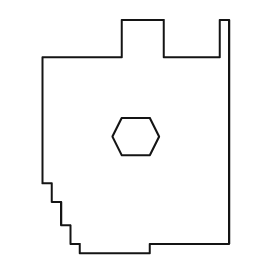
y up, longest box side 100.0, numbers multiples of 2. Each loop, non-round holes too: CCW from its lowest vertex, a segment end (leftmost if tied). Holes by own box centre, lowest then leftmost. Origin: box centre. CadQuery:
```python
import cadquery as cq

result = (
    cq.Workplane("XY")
    .moveTo(-24.0, -50.0)
    .lineTo(6.0, -50.0)
    .lineTo(6.0, -46.0)
    .lineTo(40.0, -46.0)
    .lineTo(40.0, 50.0)
    .lineTo(36.0, 50.0)
    .lineTo(36.0, 34.0)
    .lineTo(12.0, 34.0)
    .lineTo(12.0, 50.0)
    .lineTo(-6.0, 50.0)
    .lineTo(-6.0, 34.0)
    .lineTo(-40.0, 34.0)
    .lineTo(-40.0, -20.0)
    .lineTo(-36.0, -20.0)
    .lineTo(-36.0, -28.0)
    .lineTo(-32.0, -28.0)
    .lineTo(-32.0, -38.0)
    .lineTo(-28.0, -38.0)
    .lineTo(-28.0, -46.0)
    .lineTo(-24.0, -46.0)
    .close()
    .moveTo(-6.0, -8.0)
    .lineTo(6.0, -8.0)
    .lineTo(10.0, 0.0)
    .lineTo(6.0, 8.0)
    .lineTo(-6.0, 8.0)
    .lineTo(-10.0, 0.0)
    .close()
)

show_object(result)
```